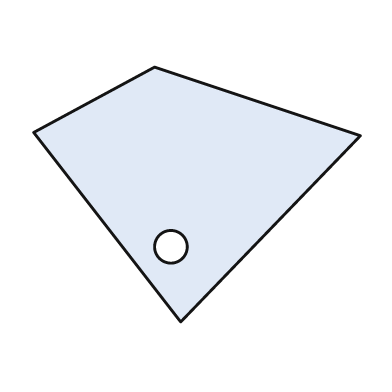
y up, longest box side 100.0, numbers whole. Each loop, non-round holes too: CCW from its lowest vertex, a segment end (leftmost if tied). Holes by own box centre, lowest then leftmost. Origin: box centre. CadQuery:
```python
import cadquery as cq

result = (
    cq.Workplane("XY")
    .moveTo(-5.0, -39.0)
    .lineTo(50.0, 18.0)
    .lineTo(-13.0, 39.0)
    .lineTo(-50.0, 19.0)
    .close()
    .moveTo(-8.0, -16.0)
    .circle(5.0)
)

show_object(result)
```